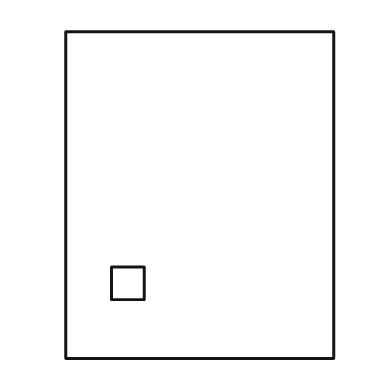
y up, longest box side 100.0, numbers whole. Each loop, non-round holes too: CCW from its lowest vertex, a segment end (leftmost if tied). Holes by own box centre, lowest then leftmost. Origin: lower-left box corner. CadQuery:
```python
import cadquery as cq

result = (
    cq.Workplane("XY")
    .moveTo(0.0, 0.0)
    .lineTo(82.0, 0.0)
    .lineTo(82.0, 100.0)
    .lineTo(0.0, 100.0)
    .close()
    .moveTo(14.0, 18.0)
    .lineTo(24.0, 18.0)
    .lineTo(24.0, 28.0)
    .lineTo(14.0, 28.0)
    .close()
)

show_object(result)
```